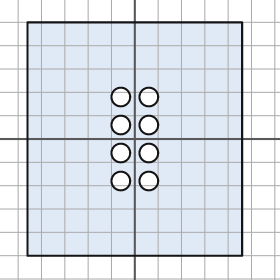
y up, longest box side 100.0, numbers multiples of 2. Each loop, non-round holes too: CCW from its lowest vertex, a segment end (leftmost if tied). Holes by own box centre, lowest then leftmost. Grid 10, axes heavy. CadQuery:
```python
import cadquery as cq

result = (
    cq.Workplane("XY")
    .moveTo(-46.0, -50.0)
    .lineTo(46.0, -50.0)
    .lineTo(46.0, 50.0)
    .lineTo(-46.0, 50.0)
    .close()
    .moveTo(-6.0, -18.0)
    .circle(4.0)
    .moveTo(6.0, -18.0)
    .circle(4.0)
    .moveTo(-6.0, -6.0)
    .circle(4.0)
    .moveTo(6.0, -6.0)
    .circle(4.0)
    .moveTo(-6.0, 6.0)
    .circle(4.0)
    .moveTo(6.0, 6.0)
    .circle(4.0)
    .moveTo(-6.0, 18.0)
    .circle(4.0)
    .moveTo(6.0, 18.0)
    .circle(4.0)
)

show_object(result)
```